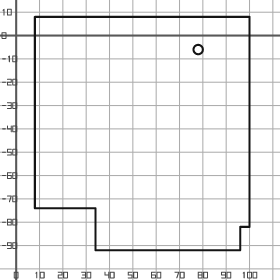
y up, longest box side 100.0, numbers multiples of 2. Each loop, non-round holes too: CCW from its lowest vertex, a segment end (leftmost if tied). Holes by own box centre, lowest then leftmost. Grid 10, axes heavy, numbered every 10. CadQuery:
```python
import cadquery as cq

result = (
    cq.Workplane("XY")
    .moveTo(34.0, -92.0)
    .lineTo(96.0, -92.0)
    .lineTo(96.0, -82.0)
    .lineTo(100.0, -82.0)
    .lineTo(100.0, 8.0)
    .lineTo(8.0, 8.0)
    .lineTo(8.0, -74.0)
    .lineTo(34.0, -74.0)
    .close()
    .moveTo(78.0, -6.0)
    .circle(2.0)
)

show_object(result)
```